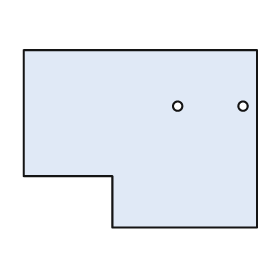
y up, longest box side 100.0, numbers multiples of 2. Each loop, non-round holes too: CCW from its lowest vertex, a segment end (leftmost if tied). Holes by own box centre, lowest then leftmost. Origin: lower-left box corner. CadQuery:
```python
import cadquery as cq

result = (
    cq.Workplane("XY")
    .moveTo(38.0, 0.0)
    .lineTo(100.0, 0.0)
    .lineTo(100.0, 76.0)
    .lineTo(0.0, 76.0)
    .lineTo(0.0, 22.0)
    .lineTo(38.0, 22.0)
    .close()
    .moveTo(66.0, 52.0)
    .circle(2.0)
    .moveTo(94.0, 52.0)
    .circle(2.0)
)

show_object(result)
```